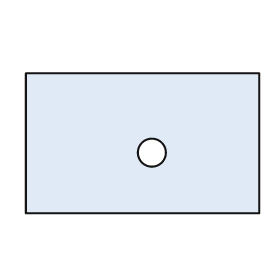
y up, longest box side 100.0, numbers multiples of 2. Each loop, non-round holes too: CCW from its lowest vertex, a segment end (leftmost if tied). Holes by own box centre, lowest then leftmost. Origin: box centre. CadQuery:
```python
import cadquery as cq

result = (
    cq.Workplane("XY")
    .moveTo(-50.0, -30.0)
    .lineTo(50.0, -30.0)
    .lineTo(50.0, 30.0)
    .lineTo(-50.0, 30.0)
    .close()
    .moveTo(4.0, -4.0)
    .circle(6.0)
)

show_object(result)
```